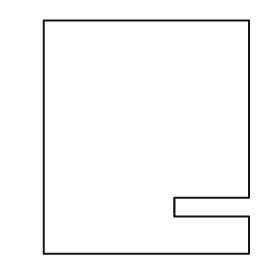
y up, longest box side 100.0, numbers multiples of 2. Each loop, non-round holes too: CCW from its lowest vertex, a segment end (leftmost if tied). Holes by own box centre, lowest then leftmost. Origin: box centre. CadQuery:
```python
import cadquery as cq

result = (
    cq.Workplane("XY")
    .moveTo(-44.0, -50.0)
    .lineTo(44.0, -50.0)
    .lineTo(44.0, -34.0)
    .lineTo(12.0, -34.0)
    .lineTo(12.0, -26.0)
    .lineTo(44.0, -26.0)
    .lineTo(44.0, 50.0)
    .lineTo(-44.0, 50.0)
    .close()
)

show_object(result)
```